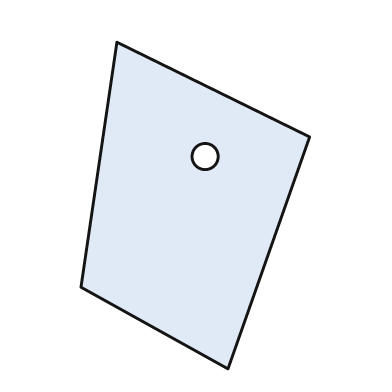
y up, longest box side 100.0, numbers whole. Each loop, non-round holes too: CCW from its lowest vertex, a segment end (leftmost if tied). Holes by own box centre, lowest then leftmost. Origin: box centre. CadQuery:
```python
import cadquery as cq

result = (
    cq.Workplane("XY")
    .moveTo(10.0, -50.0)
    .lineTo(35.0, 21.0)
    .lineTo(-24.0, 50.0)
    .lineTo(-35.0, -25.0)
    .close()
    .moveTo(3.0, 15.0)
    .circle(4.0)
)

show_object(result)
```